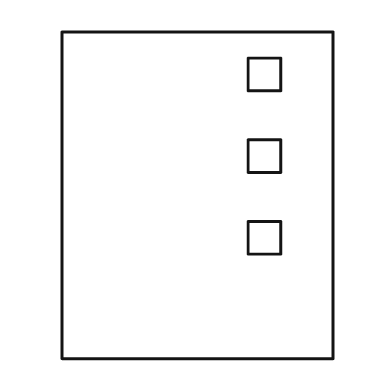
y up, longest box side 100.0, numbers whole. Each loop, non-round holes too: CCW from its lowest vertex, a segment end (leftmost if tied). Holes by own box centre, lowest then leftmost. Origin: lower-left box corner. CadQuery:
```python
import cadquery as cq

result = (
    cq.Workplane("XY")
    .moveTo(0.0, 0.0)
    .lineTo(83.0, 0.0)
    .lineTo(83.0, 100.0)
    .lineTo(0.0, 100.0)
    .close()
    .moveTo(57.0, 32.0)
    .lineTo(67.0, 32.0)
    .lineTo(67.0, 42.0)
    .lineTo(57.0, 42.0)
    .close()
    .moveTo(57.0, 57.0)
    .lineTo(67.0, 57.0)
    .lineTo(67.0, 67.0)
    .lineTo(57.0, 67.0)
    .close()
    .moveTo(57.0, 82.0)
    .lineTo(67.0, 82.0)
    .lineTo(67.0, 92.0)
    .lineTo(57.0, 92.0)
    .close()
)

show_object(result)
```